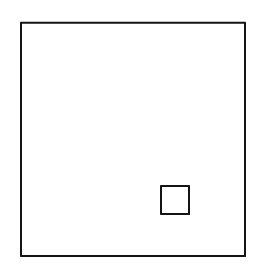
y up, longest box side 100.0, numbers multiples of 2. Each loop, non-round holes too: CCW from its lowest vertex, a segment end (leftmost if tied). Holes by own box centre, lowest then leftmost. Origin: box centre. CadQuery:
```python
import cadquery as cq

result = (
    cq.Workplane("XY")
    .moveTo(-48.0, -50.0)
    .lineTo(48.0, -50.0)
    .lineTo(48.0, 50.0)
    .lineTo(-48.0, 50.0)
    .close()
    .moveTo(12.0, -32.0)
    .lineTo(24.0, -32.0)
    .lineTo(24.0, -20.0)
    .lineTo(12.0, -20.0)
    .close()
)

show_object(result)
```